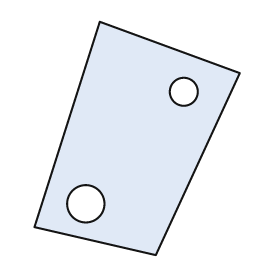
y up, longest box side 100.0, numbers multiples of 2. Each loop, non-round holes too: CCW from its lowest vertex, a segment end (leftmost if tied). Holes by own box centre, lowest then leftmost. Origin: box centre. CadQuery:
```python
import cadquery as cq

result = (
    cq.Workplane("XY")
    .moveTo(8.0, -50.0)
    .lineTo(44.0, 28.0)
    .lineTo(-16.0, 50.0)
    .lineTo(-44.0, -38.0)
    .close()
    .moveTo(-22.0, -28.0)
    .circle(8.0)
    .moveTo(20.0, 20.0)
    .circle(6.0)
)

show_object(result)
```